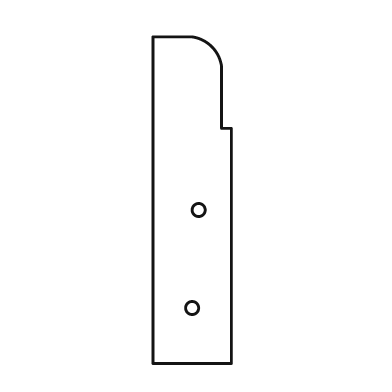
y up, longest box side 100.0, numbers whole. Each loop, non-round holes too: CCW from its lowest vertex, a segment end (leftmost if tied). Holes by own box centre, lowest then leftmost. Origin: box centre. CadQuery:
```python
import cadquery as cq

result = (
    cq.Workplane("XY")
    .moveTo(-12.0, -50.0)
    .lineTo(12.0, -50.0)
    .lineTo(12.0, 22.0)
    .lineTo(9.0, 22.0)
    .lineTo(9.0, 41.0)
    .threePointArc((6.0, 47.0), (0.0, 50.0))
    .lineTo(-12.0, 50.0)
    .close()
    .moveTo(0.0, -33.0)
    .circle(2.0)
    .moveTo(2.0, -3.0)
    .circle(2.0)
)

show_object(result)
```